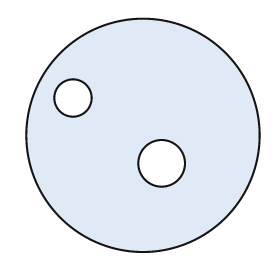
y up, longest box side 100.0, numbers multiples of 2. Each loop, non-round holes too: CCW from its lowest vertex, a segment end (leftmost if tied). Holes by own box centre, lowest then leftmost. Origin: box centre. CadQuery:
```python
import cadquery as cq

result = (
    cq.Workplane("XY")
    .moveTo(0.0, 0.0)
    .circle(50.0)
    .moveTo(8.0, -12.0)
    .circle(10.0)
    .moveTo(-30.0, 16.0)
    .circle(8.0)
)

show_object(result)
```